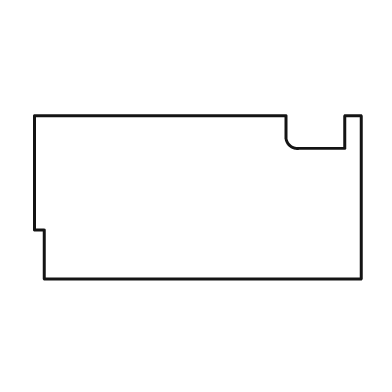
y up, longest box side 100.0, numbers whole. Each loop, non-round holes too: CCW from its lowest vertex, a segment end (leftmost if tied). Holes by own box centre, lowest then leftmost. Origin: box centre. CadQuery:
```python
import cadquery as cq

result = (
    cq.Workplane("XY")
    .moveTo(-47.0, -25.0)
    .lineTo(50.0, -25.0)
    .lineTo(50.0, 25.0)
    .lineTo(45.0, 25.0)
    .lineTo(45.0, 15.0)
    .lineTo(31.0, 15.0)
    .threePointArc((28.0, 16.0), (27.0, 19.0))
    .lineTo(27.0, 25.0)
    .lineTo(-50.0, 25.0)
    .lineTo(-50.0, -10.0)
    .lineTo(-47.0, -10.0)
    .close()
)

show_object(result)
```